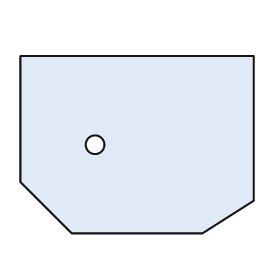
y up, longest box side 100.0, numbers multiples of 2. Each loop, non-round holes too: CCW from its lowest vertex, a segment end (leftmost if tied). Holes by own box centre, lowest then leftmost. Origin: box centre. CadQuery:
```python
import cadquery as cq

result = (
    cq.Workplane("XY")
    .moveTo(-28.0, -38.0)
    .lineTo(28.0, -38.0)
    .lineTo(50.0, -24.0)
    .lineTo(50.0, 38.0)
    .lineTo(-50.0, 38.0)
    .lineTo(-50.0, -16.0)
    .close()
    .moveTo(-18.0, 0.0)
    .circle(4.0)
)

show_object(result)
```